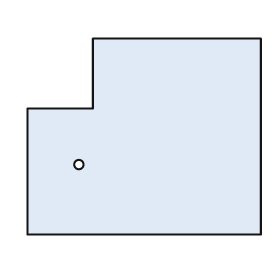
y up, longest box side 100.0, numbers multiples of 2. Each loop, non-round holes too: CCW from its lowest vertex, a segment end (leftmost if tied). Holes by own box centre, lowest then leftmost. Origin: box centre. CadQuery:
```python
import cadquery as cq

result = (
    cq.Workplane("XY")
    .moveTo(-50.0, -42.0)
    .lineTo(50.0, -42.0)
    .lineTo(50.0, 42.0)
    .lineTo(-22.0, 42.0)
    .lineTo(-22.0, 12.0)
    .lineTo(-50.0, 12.0)
    .close()
    .moveTo(-28.0, -12.0)
    .circle(2.0)
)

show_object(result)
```